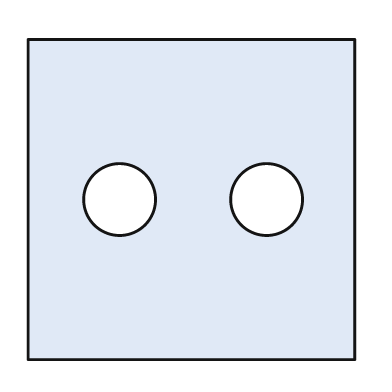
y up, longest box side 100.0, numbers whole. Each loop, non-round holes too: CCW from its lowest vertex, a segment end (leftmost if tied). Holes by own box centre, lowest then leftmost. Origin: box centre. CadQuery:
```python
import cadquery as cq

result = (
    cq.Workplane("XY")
    .moveTo(-50.0, -49.0)
    .lineTo(50.0, -49.0)
    .lineTo(50.0, 49.0)
    .lineTo(-50.0, 49.0)
    .close()
    .moveTo(-22.0, 0.0)
    .circle(11.0)
    .moveTo(23.0, 0.0)
    .circle(11.0)
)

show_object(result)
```